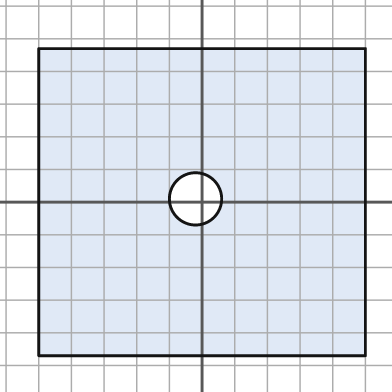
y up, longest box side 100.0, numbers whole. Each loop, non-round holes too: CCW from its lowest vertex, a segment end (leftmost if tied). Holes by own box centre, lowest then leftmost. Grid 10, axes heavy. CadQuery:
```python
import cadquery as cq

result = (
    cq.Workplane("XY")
    .moveTo(-50.0, -47.0)
    .lineTo(50.0, -47.0)
    .lineTo(50.0, 47.0)
    .lineTo(-50.0, 47.0)
    .close()
    .moveTo(-2.0, 1.0)
    .circle(8.0)
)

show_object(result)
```